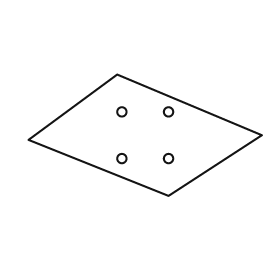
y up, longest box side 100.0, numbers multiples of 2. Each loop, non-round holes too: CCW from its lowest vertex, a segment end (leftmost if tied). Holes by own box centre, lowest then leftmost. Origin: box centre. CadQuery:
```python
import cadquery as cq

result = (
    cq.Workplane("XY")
    .moveTo(10.0, -26.0)
    .lineTo(50.0, 0.0)
    .lineTo(-12.0, 26.0)
    .lineTo(-50.0, -2.0)
    .close()
    .moveTo(-10.0, -10.0)
    .circle(2.0)
    .moveTo(10.0, -10.0)
    .circle(2.0)
    .moveTo(-10.0, 10.0)
    .circle(2.0)
    .moveTo(10.0, 10.0)
    .circle(2.0)
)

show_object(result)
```